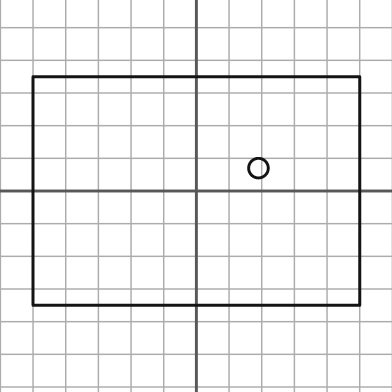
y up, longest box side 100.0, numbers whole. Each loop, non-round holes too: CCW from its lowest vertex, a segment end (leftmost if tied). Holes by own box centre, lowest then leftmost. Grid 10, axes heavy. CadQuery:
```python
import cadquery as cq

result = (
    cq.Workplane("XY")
    .moveTo(-50.0, -35.0)
    .lineTo(50.0, -35.0)
    .lineTo(50.0, 35.0)
    .lineTo(-50.0, 35.0)
    .close()
    .moveTo(19.0, 7.0)
    .circle(3.0)
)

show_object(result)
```